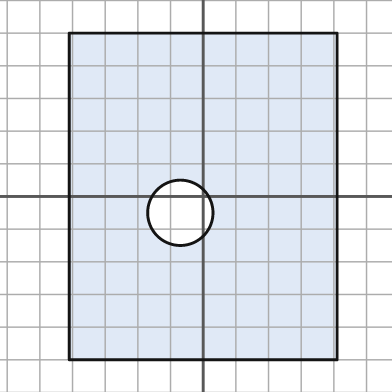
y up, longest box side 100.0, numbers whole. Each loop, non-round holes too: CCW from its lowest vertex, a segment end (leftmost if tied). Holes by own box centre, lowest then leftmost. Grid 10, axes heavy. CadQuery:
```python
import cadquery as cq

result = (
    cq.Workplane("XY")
    .moveTo(-41.0, -50.0)
    .lineTo(41.0, -50.0)
    .lineTo(41.0, 50.0)
    .lineTo(-41.0, 50.0)
    .close()
    .moveTo(-7.0, -5.0)
    .circle(10.0)
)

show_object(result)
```